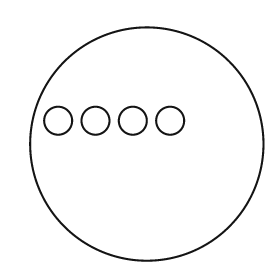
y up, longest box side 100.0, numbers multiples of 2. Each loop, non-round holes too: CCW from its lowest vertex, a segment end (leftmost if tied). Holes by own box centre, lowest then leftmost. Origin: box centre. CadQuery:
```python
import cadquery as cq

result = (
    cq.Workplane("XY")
    .moveTo(0.0, 0.0)
    .circle(50.0)
    .moveTo(-38.0, 10.0)
    .circle(6.0)
    .moveTo(-22.0, 10.0)
    .circle(6.0)
    .moveTo(-6.0, 10.0)
    .circle(6.0)
    .moveTo(10.0, 10.0)
    .circle(6.0)
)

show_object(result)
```